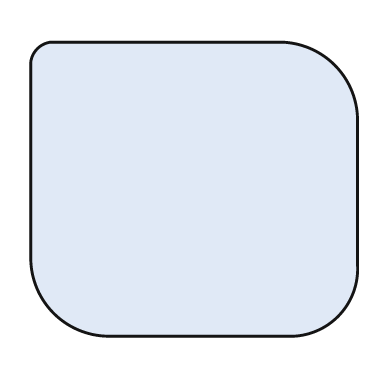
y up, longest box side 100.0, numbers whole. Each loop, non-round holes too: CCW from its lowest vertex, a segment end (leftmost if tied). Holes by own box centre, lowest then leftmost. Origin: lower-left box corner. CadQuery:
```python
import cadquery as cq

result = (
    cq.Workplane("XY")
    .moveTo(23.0, 0.0)
    .lineTo(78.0, 0.0)
    .threePointArc((94.0, 6.0), (100.0, 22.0))
    .lineTo(100.0, 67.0)
    .threePointArc((93.0, 83.0), (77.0, 90.0))
    .lineTo(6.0, 90.0)
    .threePointArc((2.0, 88.0), (0.0, 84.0))
    .lineTo(0.0, 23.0)
    .threePointArc((7.0, 7.0), (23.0, 0.0))
    .close()
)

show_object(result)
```